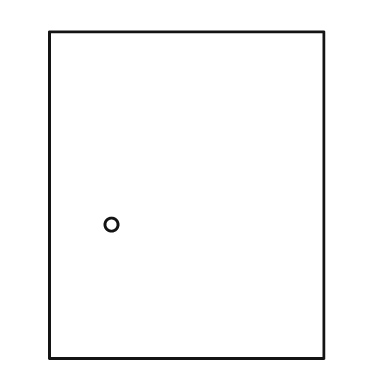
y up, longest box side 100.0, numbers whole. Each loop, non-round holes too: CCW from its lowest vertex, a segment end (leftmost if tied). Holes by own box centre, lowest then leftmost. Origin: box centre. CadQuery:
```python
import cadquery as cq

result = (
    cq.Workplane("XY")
    .moveTo(-42.0, -50.0)
    .lineTo(42.0, -50.0)
    .lineTo(42.0, 50.0)
    .lineTo(-42.0, 50.0)
    .close()
    .moveTo(-23.0, -9.0)
    .circle(2.0)
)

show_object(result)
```